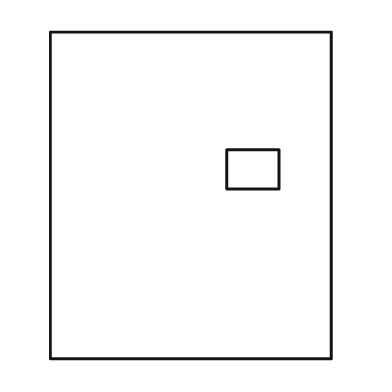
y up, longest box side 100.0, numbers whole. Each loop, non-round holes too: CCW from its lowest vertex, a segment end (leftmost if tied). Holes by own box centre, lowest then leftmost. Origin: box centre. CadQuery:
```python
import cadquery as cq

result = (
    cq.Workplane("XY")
    .moveTo(-43.0, -50.0)
    .lineTo(43.0, -50.0)
    .lineTo(43.0, 50.0)
    .lineTo(-43.0, 50.0)
    .close()
    .moveTo(11.0, 2.0)
    .lineTo(27.0, 2.0)
    .lineTo(27.0, 14.0)
    .lineTo(11.0, 14.0)
    .close()
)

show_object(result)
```